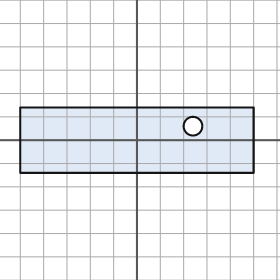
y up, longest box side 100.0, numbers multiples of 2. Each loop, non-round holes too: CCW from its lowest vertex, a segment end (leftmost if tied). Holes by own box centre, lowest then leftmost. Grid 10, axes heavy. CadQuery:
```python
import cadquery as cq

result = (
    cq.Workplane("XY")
    .moveTo(-50.0, -14.0)
    .lineTo(50.0, -14.0)
    .lineTo(50.0, 14.0)
    .lineTo(-50.0, 14.0)
    .close()
    .moveTo(24.0, 6.0)
    .circle(4.0)
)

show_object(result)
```